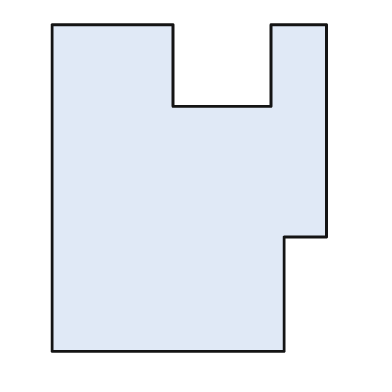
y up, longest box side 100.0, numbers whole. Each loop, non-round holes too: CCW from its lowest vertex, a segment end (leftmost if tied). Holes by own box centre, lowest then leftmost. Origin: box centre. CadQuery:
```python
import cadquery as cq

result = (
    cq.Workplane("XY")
    .moveTo(-42.0, -50.0)
    .lineTo(29.0, -50.0)
    .lineTo(29.0, -15.0)
    .lineTo(42.0, -15.0)
    .lineTo(42.0, 50.0)
    .lineTo(25.0, 50.0)
    .lineTo(25.0, 25.0)
    .lineTo(-5.0, 25.0)
    .lineTo(-5.0, 50.0)
    .lineTo(-42.0, 50.0)
    .close()
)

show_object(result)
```